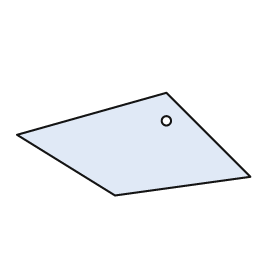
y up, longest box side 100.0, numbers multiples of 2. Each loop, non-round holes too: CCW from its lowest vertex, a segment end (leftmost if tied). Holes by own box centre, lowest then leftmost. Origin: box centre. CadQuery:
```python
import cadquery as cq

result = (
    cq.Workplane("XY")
    .moveTo(-8.0, -22.0)
    .lineTo(50.0, -14.0)
    .lineTo(14.0, 22.0)
    .lineTo(-50.0, 4.0)
    .close()
    .moveTo(14.0, 10.0)
    .circle(2.0)
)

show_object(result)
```